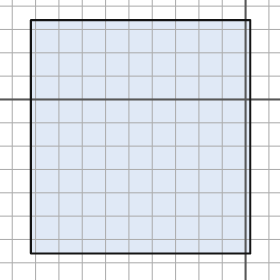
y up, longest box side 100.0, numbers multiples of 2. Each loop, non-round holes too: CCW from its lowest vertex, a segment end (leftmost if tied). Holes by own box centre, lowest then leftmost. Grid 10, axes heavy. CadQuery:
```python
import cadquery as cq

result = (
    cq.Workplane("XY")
    .moveTo(-92.0, -66.0)
    .lineTo(2.0, -66.0)
    .lineTo(2.0, 34.0)
    .lineTo(-92.0, 34.0)
    .close()
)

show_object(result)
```